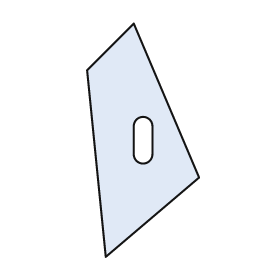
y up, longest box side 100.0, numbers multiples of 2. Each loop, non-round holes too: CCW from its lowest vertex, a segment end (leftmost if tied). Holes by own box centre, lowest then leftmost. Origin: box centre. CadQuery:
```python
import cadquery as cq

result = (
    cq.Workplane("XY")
    .moveTo(-16.0, -50.0)
    .lineTo(24.0, -16.0)
    .lineTo(-4.0, 50.0)
    .lineTo(-24.0, 30.0)
    .close()
    .moveTo(-4.0, -6.0)
    .threePointArc((0.0, -10.0), (4.0, -6.0))
    .lineTo(4.0, 6.0)
    .threePointArc((0.0, 10.0), (-4.0, 6.0))
    .close()
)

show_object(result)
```